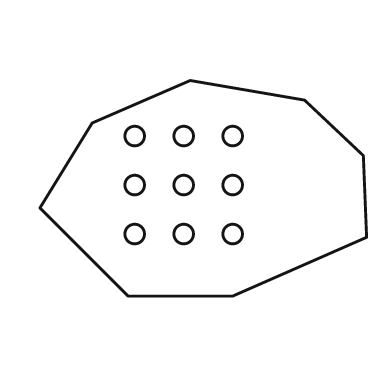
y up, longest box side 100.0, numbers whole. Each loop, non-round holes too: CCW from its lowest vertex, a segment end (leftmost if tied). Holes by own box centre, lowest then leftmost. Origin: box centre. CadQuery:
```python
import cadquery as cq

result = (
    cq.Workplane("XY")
    .moveTo(-23.0, -33.0)
    .lineTo(9.0, -33.0)
    .lineTo(50.0, -15.0)
    .lineTo(49.0, 10.0)
    .lineTo(31.0, 27.0)
    .lineTo(-4.0, 33.0)
    .lineTo(-34.0, 20.0)
    .lineTo(-50.0, -6.0)
    .close()
    .moveTo(-21.0, -14.0)
    .circle(3.0)
    .moveTo(-6.0, -14.0)
    .circle(3.0)
    .moveTo(9.0, -14.0)
    .circle(3.0)
    .moveTo(-21.0, 1.0)
    .circle(3.0)
    .moveTo(-6.0, 1.0)
    .circle(3.0)
    .moveTo(9.0, 1.0)
    .circle(3.0)
    .moveTo(-21.0, 16.0)
    .circle(3.0)
    .moveTo(-6.0, 16.0)
    .circle(3.0)
    .moveTo(9.0, 16.0)
    .circle(3.0)
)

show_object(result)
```